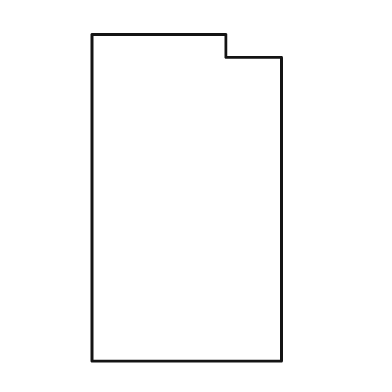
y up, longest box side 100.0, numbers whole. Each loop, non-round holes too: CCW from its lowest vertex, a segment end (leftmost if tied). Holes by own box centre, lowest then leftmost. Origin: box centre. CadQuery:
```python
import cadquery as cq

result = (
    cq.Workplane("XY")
    .moveTo(-29.0, -50.0)
    .lineTo(29.0, -50.0)
    .lineTo(29.0, 43.0)
    .lineTo(12.0, 43.0)
    .lineTo(12.0, 50.0)
    .lineTo(-29.0, 50.0)
    .close()
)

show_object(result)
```